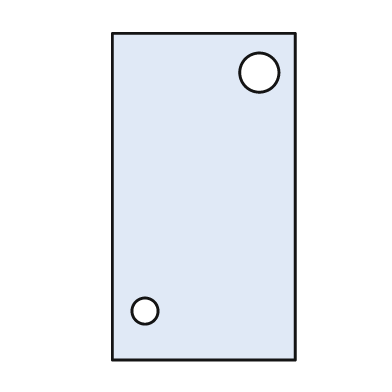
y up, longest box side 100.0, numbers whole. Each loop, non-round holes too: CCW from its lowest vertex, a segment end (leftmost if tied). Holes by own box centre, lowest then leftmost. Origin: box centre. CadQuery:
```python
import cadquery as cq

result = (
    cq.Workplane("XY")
    .moveTo(-28.0, -50.0)
    .lineTo(28.0, -50.0)
    .lineTo(28.0, 50.0)
    .lineTo(-28.0, 50.0)
    .close()
    .moveTo(-18.0, -35.0)
    .circle(4.0)
    .moveTo(17.0, 38.0)
    .circle(6.0)
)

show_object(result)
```